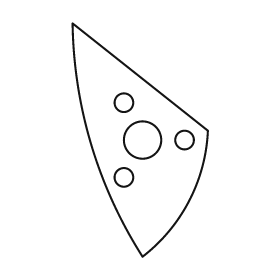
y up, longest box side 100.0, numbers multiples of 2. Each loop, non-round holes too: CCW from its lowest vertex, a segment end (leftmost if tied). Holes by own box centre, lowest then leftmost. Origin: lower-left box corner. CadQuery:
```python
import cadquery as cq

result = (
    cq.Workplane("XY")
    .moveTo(30.0, 0.0)
    .threePointArc((50.0, 24.0), (58.0, 54.0))
    .lineTo(0.0, 100.0)
    .threePointArc((8.0, 48.0), (30.0, 0.0))
    .close()
    .moveTo(22.0, 34.0)
    .circle(4.0)
    .moveTo(30.0, 50.0)
    .circle(8.0)
    .moveTo(48.0, 50.0)
    .circle(4.0)
    .moveTo(22.0, 66.0)
    .circle(4.0)
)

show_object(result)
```